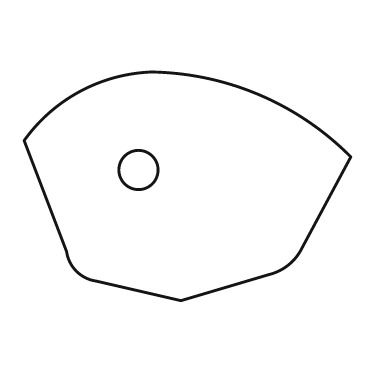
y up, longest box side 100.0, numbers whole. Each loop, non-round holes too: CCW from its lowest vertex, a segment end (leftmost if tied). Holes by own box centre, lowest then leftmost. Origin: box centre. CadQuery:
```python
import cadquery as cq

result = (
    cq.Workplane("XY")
    .moveTo(-2.0, -35.0)
    .lineTo(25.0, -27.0)
    .threePointArc((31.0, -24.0), (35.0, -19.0))
    .lineTo(50.0, 9.0)
    .threePointArc((22.0, 28.0), (-11.0, 35.0))
    .threePointArc((-33.0, 29.0), (-50.0, 14.0))
    .lineTo(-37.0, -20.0)
    .threePointArc((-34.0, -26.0), (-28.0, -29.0))
    .close()
    .moveTo(-15.0, 5.0)
    .circle(6.0)
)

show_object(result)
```